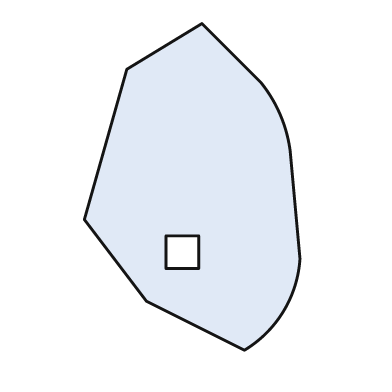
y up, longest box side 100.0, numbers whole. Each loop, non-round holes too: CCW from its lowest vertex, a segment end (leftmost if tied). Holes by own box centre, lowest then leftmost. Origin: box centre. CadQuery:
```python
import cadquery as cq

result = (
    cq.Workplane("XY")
    .moveTo(16.0, -50.0)
    .threePointArc((28.0, -38.0), (33.0, -22.0))
    .lineTo(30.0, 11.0)
    .threePointArc((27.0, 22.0), (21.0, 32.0))
    .lineTo(3.0, 50.0)
    .lineTo(-20.0, 36.0)
    .lineTo(-33.0, -10.0)
    .lineTo(-14.0, -35.0)
    .close()
    .moveTo(-8.0, -25.0)
    .lineTo(2.0, -25.0)
    .lineTo(2.0, -15.0)
    .lineTo(-8.0, -15.0)
    .close()
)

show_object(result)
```